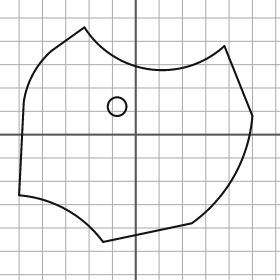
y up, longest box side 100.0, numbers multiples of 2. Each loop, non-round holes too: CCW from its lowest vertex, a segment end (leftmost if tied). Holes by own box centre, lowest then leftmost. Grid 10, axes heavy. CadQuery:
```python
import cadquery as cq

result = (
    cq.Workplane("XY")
    .moveTo(-14.0, -46.0)
    .lineTo(24.0, -38.0)
    .threePointArc((42.0, -18.0), (50.0, 8.0))
    .lineTo(38.0, 38.0)
    .threePointArc((6.0, 28.0), (-22.0, 46.0))
    .lineTo(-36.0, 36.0)
    .threePointArc((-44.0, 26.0), (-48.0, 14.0))
    .lineTo(-50.0, -26.0)
    .threePointArc((-30.0, -32.0), (-14.0, -46.0))
    .close()
    .moveTo(-8.0, 12.0)
    .circle(4.0)
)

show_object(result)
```